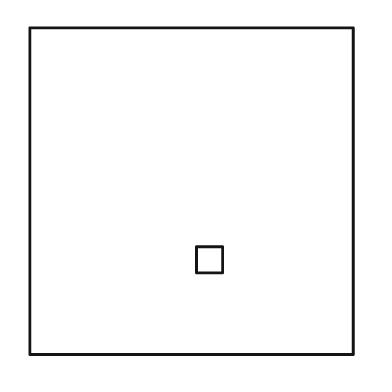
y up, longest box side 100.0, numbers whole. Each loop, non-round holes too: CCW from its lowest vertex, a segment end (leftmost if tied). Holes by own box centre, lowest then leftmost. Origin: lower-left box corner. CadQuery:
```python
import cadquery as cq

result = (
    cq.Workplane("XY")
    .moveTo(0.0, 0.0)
    .lineTo(99.0, 0.0)
    .lineTo(99.0, 100.0)
    .lineTo(0.0, 100.0)
    .close()
    .moveTo(51.0, 25.0)
    .lineTo(59.0, 25.0)
    .lineTo(59.0, 33.0)
    .lineTo(51.0, 33.0)
    .close()
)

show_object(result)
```